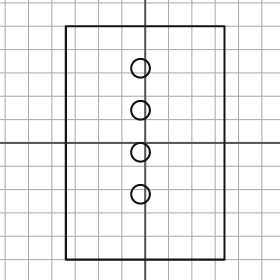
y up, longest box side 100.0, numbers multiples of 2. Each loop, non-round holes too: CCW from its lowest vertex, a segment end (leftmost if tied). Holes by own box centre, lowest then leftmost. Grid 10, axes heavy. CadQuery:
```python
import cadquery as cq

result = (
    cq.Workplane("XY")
    .moveTo(-34.0, -50.0)
    .lineTo(34.0, -50.0)
    .lineTo(34.0, 50.0)
    .lineTo(-34.0, 50.0)
    .close()
    .moveTo(-2.0, -22.0)
    .circle(4.0)
    .moveTo(-2.0, -4.0)
    .circle(4.0)
    .moveTo(-2.0, 14.0)
    .circle(4.0)
    .moveTo(-2.0, 32.0)
    .circle(4.0)
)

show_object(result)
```